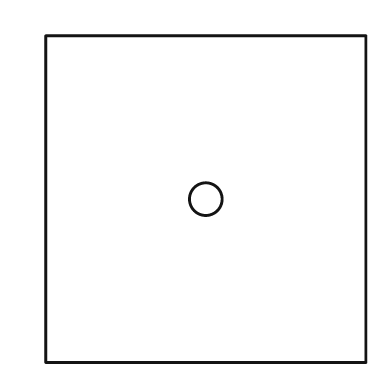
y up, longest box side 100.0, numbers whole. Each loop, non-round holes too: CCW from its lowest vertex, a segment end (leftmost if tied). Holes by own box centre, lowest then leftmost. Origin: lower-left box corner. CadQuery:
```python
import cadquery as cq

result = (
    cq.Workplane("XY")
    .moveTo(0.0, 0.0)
    .lineTo(98.0, 0.0)
    .lineTo(98.0, 100.0)
    .lineTo(0.0, 100.0)
    .close()
    .moveTo(49.0, 50.0)
    .circle(5.0)
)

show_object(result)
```